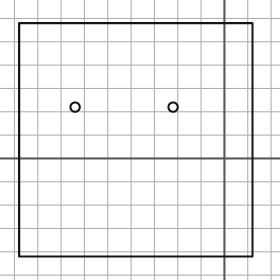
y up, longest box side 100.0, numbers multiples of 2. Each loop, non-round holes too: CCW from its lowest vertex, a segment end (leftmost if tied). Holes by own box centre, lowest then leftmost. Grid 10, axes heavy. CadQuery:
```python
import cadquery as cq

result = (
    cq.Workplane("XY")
    .moveTo(-88.0, -42.0)
    .lineTo(12.0, -42.0)
    .lineTo(12.0, 58.0)
    .lineTo(-88.0, 58.0)
    .close()
    .moveTo(-64.0, 22.0)
    .circle(2.0)
    .moveTo(-22.0, 22.0)
    .circle(2.0)
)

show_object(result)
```